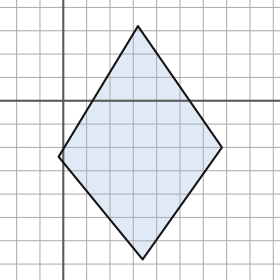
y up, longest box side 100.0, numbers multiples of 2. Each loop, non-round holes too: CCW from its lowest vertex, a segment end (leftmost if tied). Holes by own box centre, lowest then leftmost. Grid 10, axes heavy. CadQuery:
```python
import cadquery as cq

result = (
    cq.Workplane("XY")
    .moveTo(34.0, -68.0)
    .lineTo(68.0, -20.0)
    .lineTo(32.0, 32.0)
    .lineTo(-2.0, -24.0)
    .close()
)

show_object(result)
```